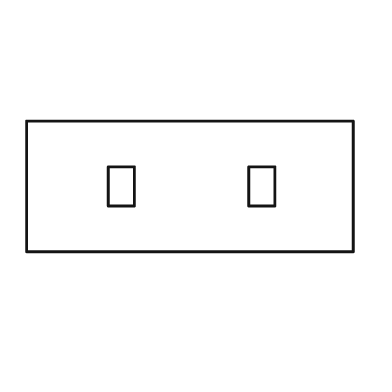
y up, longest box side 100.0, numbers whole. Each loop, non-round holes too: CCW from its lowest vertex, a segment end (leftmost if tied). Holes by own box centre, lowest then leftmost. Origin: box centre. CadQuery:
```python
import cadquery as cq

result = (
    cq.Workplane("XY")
    .moveTo(-50.0, -20.0)
    .lineTo(50.0, -20.0)
    .lineTo(50.0, 20.0)
    .lineTo(-50.0, 20.0)
    .close()
    .moveTo(-25.0, -6.0)
    .lineTo(-17.0, -6.0)
    .lineTo(-17.0, 6.0)
    .lineTo(-25.0, 6.0)
    .close()
    .moveTo(18.0, -6.0)
    .lineTo(26.0, -6.0)
    .lineTo(26.0, 6.0)
    .lineTo(18.0, 6.0)
    .close()
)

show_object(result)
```